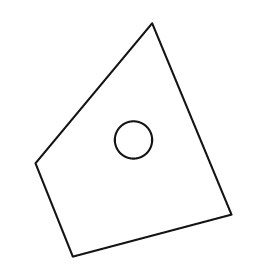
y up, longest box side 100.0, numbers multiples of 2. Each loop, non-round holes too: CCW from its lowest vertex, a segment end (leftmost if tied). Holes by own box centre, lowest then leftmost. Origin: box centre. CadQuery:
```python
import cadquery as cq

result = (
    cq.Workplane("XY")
    .moveTo(-26.0, -50.0)
    .lineTo(42.0, -32.0)
    .lineTo(8.0, 50.0)
    .lineTo(-42.0, -10.0)
    .close()
    .moveTo(0.0, 0.0)
    .circle(8.0)
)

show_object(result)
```